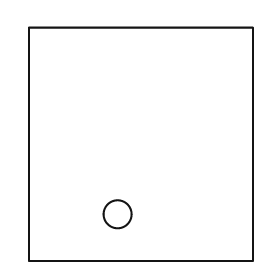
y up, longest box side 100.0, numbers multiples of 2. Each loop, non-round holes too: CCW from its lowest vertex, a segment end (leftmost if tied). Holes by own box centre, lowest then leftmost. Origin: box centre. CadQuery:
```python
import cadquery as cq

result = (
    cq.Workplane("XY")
    .moveTo(-48.0, -50.0)
    .lineTo(48.0, -50.0)
    .lineTo(48.0, 50.0)
    .lineTo(-48.0, 50.0)
    .close()
    .moveTo(-10.0, -30.0)
    .circle(6.0)
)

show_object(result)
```